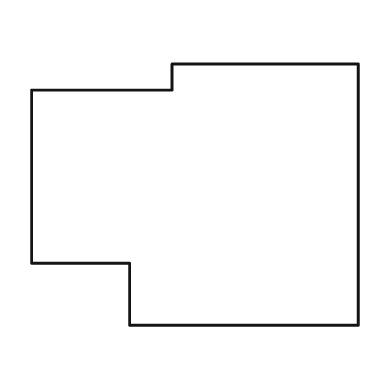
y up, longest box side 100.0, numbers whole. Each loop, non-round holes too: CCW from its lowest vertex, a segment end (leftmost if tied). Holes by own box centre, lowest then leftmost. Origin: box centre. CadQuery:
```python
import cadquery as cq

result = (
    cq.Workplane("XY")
    .moveTo(-20.0, -40.0)
    .lineTo(50.0, -40.0)
    .lineTo(50.0, 40.0)
    .lineTo(-7.0, 40.0)
    .lineTo(-7.0, 32.0)
    .lineTo(-50.0, 32.0)
    .lineTo(-50.0, -21.0)
    .lineTo(-20.0, -21.0)
    .close()
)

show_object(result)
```